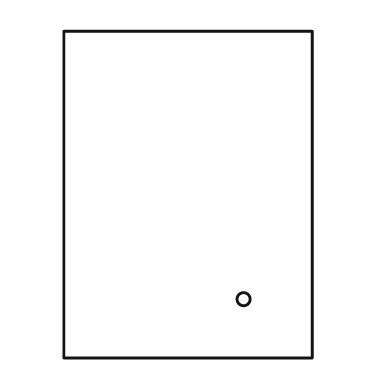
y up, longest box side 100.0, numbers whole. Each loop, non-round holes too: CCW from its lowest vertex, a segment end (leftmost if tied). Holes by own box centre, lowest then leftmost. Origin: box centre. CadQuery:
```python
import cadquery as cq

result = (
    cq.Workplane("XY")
    .moveTo(-38.0, -50.0)
    .lineTo(38.0, -50.0)
    .lineTo(38.0, 50.0)
    .lineTo(-38.0, 50.0)
    .close()
    .moveTo(17.0, -32.0)
    .circle(2.0)
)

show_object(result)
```